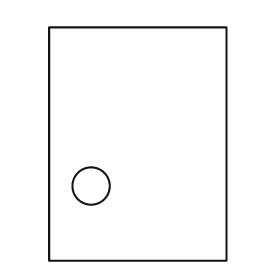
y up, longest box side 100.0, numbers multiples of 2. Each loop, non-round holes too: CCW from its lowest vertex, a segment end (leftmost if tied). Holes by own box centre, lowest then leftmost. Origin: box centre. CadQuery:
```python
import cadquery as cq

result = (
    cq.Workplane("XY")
    .moveTo(-38.0, -50.0)
    .lineTo(38.0, -50.0)
    .lineTo(38.0, 50.0)
    .lineTo(-38.0, 50.0)
    .close()
    .moveTo(-20.0, -18.0)
    .circle(8.0)
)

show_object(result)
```